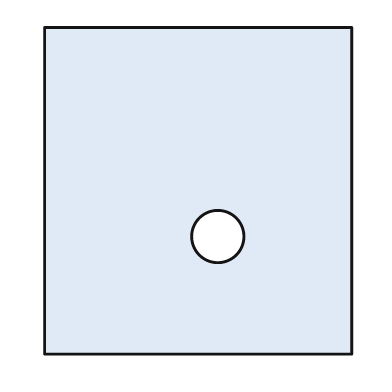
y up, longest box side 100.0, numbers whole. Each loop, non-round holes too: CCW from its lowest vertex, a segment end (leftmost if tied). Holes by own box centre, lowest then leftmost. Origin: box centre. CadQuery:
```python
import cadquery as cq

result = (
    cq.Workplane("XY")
    .moveTo(-47.0, -50.0)
    .lineTo(47.0, -50.0)
    .lineTo(47.0, 50.0)
    .lineTo(-47.0, 50.0)
    .close()
    .moveTo(6.0, -14.0)
    .circle(8.0)
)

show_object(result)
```